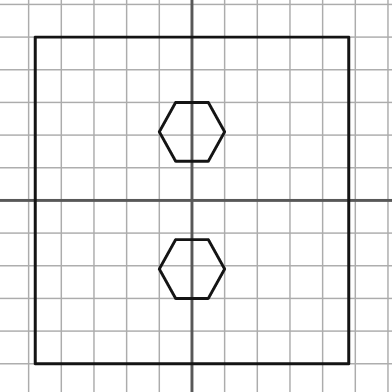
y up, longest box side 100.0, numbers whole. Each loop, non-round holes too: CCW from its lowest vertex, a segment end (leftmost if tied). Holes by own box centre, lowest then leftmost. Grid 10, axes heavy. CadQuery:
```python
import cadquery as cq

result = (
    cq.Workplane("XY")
    .moveTo(-48.0, -50.0)
    .lineTo(48.0, -50.0)
    .lineTo(48.0, 50.0)
    .lineTo(-48.0, 50.0)
    .close()
    .moveTo(-5.0, -30.0)
    .lineTo(5.0, -30.0)
    .lineTo(10.0, -21.0)
    .lineTo(5.0, -12.0)
    .lineTo(-5.0, -12.0)
    .lineTo(-10.0, -21.0)
    .close()
    .moveTo(-5.0, 12.0)
    .lineTo(5.0, 12.0)
    .lineTo(10.0, 21.0)
    .lineTo(5.0, 30.0)
    .lineTo(-5.0, 30.0)
    .lineTo(-10.0, 21.0)
    .close()
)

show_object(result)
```